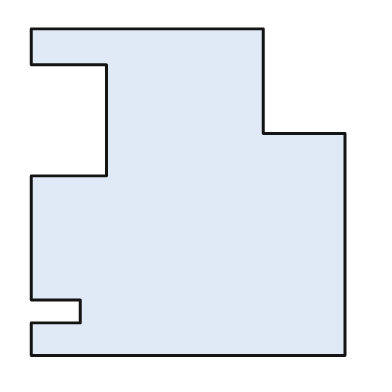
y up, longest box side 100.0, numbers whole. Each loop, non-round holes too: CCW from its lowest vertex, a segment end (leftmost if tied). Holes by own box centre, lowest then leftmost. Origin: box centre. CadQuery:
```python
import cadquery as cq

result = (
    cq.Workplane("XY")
    .moveTo(-48.0, -50.0)
    .lineTo(48.0, -50.0)
    .lineTo(48.0, 18.0)
    .lineTo(23.0, 18.0)
    .lineTo(23.0, 50.0)
    .lineTo(-48.0, 50.0)
    .lineTo(-48.0, 39.0)
    .lineTo(-25.0, 39.0)
    .lineTo(-25.0, 5.0)
    .lineTo(-48.0, 5.0)
    .lineTo(-48.0, -33.0)
    .lineTo(-33.0, -33.0)
    .lineTo(-33.0, -40.0)
    .lineTo(-48.0, -40.0)
    .close()
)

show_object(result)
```